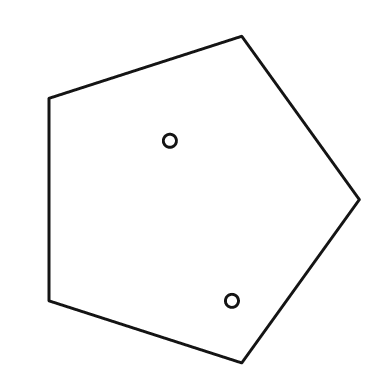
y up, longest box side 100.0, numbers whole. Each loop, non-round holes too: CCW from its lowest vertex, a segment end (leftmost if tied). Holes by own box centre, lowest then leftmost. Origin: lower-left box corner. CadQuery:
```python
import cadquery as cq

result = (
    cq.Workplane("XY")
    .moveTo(59.0, 0.0)
    .lineTo(95.0, 50.0)
    .lineTo(59.0, 100.0)
    .lineTo(0.0, 81.0)
    .lineTo(0.0, 19.0)
    .close()
    .moveTo(56.0, 19.0)
    .circle(2.0)
    .moveTo(37.0, 68.0)
    .circle(2.0)
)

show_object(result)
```